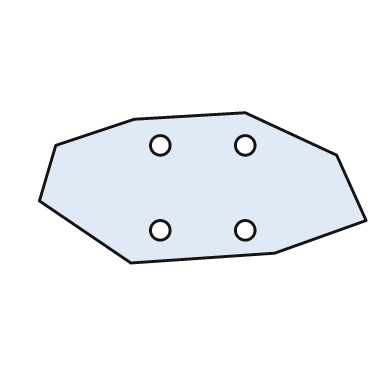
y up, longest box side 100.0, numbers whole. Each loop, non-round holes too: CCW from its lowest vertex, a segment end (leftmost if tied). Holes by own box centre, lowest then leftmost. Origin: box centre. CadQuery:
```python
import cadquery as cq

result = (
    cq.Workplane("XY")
    .moveTo(-22.0, -23.0)
    .lineTo(22.0, -20.0)
    .lineTo(50.0, -10.0)
    .lineTo(41.0, 10.0)
    .lineTo(13.0, 23.0)
    .lineTo(-21.0, 21.0)
    .lineTo(-45.0, 13.0)
    .lineTo(-50.0, -4.0)
    .close()
    .moveTo(-13.0, -13.0)
    .circle(3.0)
    .moveTo(13.0, -13.0)
    .circle(3.0)
    .moveTo(-13.0, 13.0)
    .circle(3.0)
    .moveTo(13.0, 13.0)
    .circle(3.0)
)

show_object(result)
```